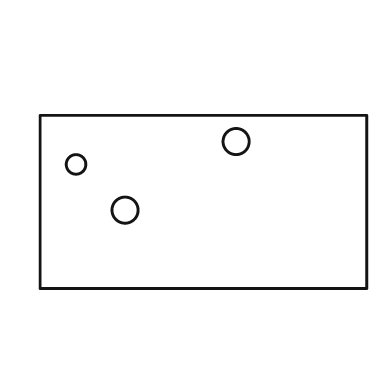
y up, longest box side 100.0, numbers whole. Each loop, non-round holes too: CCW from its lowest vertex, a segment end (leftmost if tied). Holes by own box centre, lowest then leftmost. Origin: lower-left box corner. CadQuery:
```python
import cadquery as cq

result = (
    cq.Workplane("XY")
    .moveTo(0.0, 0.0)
    .lineTo(100.0, 0.0)
    .lineTo(100.0, 53.0)
    .lineTo(0.0, 53.0)
    .close()
    .moveTo(26.0, 24.0)
    .circle(4.0)
    .moveTo(11.0, 38.0)
    .circle(3.0)
    .moveTo(60.0, 45.0)
    .circle(4.0)
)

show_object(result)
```